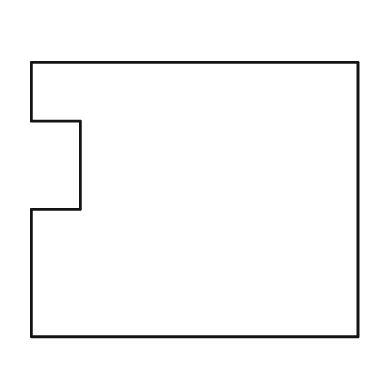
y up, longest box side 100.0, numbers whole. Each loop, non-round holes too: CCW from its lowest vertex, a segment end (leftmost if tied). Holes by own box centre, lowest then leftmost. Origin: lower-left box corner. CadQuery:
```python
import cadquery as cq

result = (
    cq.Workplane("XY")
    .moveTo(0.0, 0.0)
    .lineTo(100.0, 0.0)
    .lineTo(100.0, 84.0)
    .lineTo(0.0, 84.0)
    .lineTo(0.0, 66.0)
    .lineTo(15.0, 66.0)
    .lineTo(15.0, 39.0)
    .lineTo(0.0, 39.0)
    .close()
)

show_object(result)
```